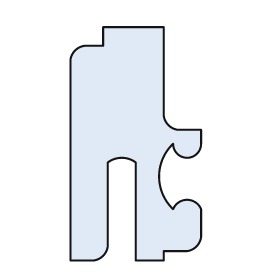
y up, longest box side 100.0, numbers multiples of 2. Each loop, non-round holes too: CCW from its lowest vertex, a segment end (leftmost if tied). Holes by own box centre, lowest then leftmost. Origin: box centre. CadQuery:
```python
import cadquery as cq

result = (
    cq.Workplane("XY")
    .moveTo(-28.0, -50.0)
    .lineTo(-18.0, -50.0)
    .threePointArc((-14.0, -48.0), (-12.0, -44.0))
    .lineTo(-12.0, -8.0)
    .threePointArc((-6.0, -6.0), (0.0, -8.0))
    .lineTo(0.0, -50.0)
    .lineTo(12.0, -50.0)
    .lineTo(12.0, -46.0)
    .lineTo(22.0, -46.0)
    .threePointArc((26.0, -44.0), (28.0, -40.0))
    .lineTo(28.0, -28.0)
    .threePointArc((22.0, -24.0), (16.0, -28.0))
    .threePointArc((10.0, -14.0), (16.0, 0.0))
    .threePointArc((22.0, -6.0), (28.0, 0.0))
    .lineTo(28.0, 6.0)
    .lineTo(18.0, 6.0)
    .threePointArc((14.0, 8.0), (12.0, 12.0))
    .lineTo(12.0, 50.0)
    .lineTo(-14.0, 50.0)
    .lineTo(-14.0, 42.0)
    .lineTo(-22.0, 42.0)
    .threePointArc((-26.0, 40.0), (-28.0, 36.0))
    .close()
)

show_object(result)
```